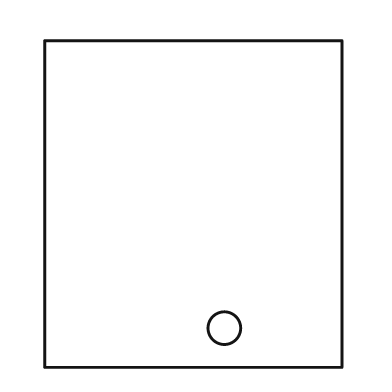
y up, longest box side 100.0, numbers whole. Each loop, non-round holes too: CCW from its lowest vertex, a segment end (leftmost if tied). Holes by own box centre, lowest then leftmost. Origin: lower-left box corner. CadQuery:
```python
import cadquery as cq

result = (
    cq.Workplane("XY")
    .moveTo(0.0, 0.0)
    .lineTo(91.0, 0.0)
    .lineTo(91.0, 100.0)
    .lineTo(0.0, 100.0)
    .close()
    .moveTo(55.0, 12.0)
    .circle(5.0)
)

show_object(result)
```